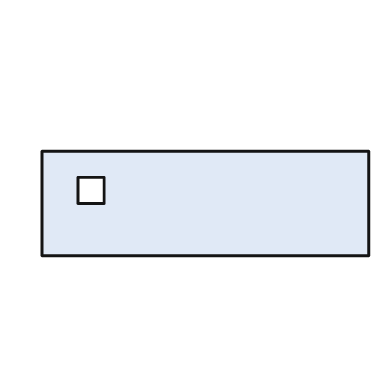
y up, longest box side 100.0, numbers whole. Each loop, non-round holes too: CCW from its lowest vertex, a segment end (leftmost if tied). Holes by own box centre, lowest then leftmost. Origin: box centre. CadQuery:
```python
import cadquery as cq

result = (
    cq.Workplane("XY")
    .moveTo(-50.0, -16.0)
    .lineTo(50.0, -16.0)
    .lineTo(50.0, 16.0)
    .lineTo(-50.0, 16.0)
    .close()
    .moveTo(-39.0, 0.0)
    .lineTo(-31.0, 0.0)
    .lineTo(-31.0, 8.0)
    .lineTo(-39.0, 8.0)
    .close()
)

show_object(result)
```